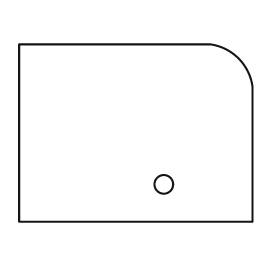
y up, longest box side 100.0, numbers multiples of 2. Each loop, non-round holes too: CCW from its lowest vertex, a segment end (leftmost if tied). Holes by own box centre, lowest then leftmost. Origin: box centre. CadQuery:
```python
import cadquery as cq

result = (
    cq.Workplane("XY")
    .moveTo(-50.0, -38.0)
    .lineTo(50.0, -38.0)
    .lineTo(50.0, 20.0)
    .threePointArc((44.0, 32.0), (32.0, 38.0))
    .lineTo(-50.0, 38.0)
    .close()
    .moveTo(12.0, -22.0)
    .circle(4.0)
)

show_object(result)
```